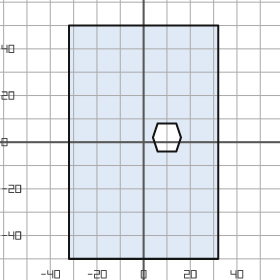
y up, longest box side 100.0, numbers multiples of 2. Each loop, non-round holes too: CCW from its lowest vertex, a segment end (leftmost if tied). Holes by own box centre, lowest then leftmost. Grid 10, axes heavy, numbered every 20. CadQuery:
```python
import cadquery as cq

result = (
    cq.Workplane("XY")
    .moveTo(-32.0, -50.0)
    .lineTo(32.0, -50.0)
    .lineTo(32.0, 50.0)
    .lineTo(-32.0, 50.0)
    .close()
    .moveTo(6.0, -4.0)
    .lineTo(14.0, -4.0)
    .lineTo(16.0, 2.0)
    .lineTo(14.0, 8.0)
    .lineTo(6.0, 8.0)
    .lineTo(4.0, 2.0)
    .close()
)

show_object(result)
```